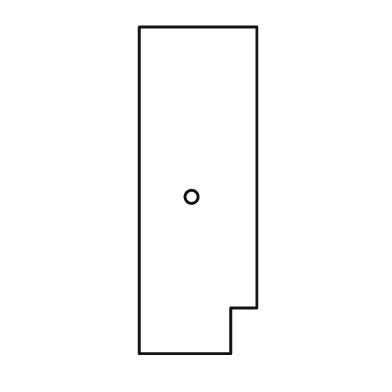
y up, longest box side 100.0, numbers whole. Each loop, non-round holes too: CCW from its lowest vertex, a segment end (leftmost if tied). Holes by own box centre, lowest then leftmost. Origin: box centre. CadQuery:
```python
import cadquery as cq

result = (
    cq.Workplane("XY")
    .moveTo(-18.0, -50.0)
    .lineTo(10.0, -50.0)
    .lineTo(10.0, -36.0)
    .lineTo(18.0, -36.0)
    .lineTo(18.0, 50.0)
    .lineTo(-18.0, 50.0)
    .close()
    .moveTo(-2.0, -2.0)
    .circle(2.0)
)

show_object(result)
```